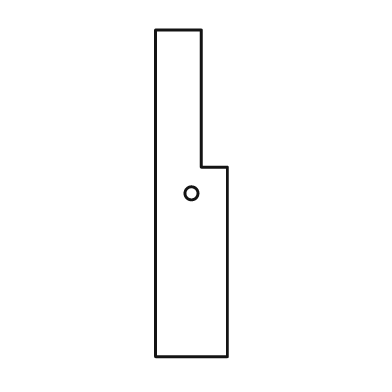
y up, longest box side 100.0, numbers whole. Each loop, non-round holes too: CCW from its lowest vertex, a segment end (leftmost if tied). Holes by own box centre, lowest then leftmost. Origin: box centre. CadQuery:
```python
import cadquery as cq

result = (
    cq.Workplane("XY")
    .moveTo(-11.0, -50.0)
    .lineTo(11.0, -50.0)
    .lineTo(11.0, 8.0)
    .lineTo(3.0, 8.0)
    .lineTo(3.0, 50.0)
    .lineTo(-11.0, 50.0)
    .close()
    .moveTo(0.0, 0.0)
    .circle(2.0)
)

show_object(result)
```